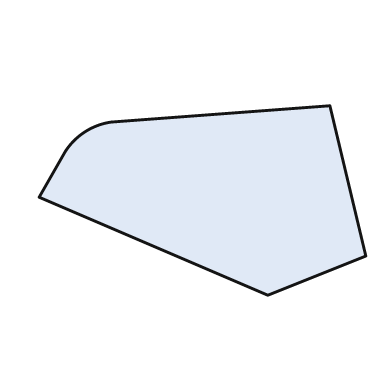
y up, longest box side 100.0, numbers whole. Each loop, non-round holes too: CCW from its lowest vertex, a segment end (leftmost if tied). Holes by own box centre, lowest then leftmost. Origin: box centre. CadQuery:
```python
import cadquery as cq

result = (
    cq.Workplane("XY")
    .moveTo(20.0, -29.0)
    .lineTo(50.0, -17.0)
    .lineTo(39.0, 29.0)
    .lineTo(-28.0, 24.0)
    .threePointArc((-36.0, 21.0), (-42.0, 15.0))
    .lineTo(-50.0, 1.0)
    .close()
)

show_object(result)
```